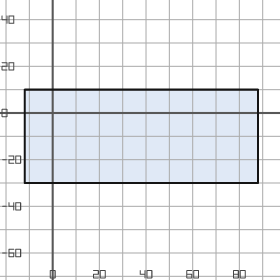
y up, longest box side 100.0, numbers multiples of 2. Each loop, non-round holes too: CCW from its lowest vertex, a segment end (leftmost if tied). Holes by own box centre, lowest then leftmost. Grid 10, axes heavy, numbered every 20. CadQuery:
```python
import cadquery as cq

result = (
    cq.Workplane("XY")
    .moveTo(-12.0, -30.0)
    .lineTo(88.0, -30.0)
    .lineTo(88.0, 10.0)
    .lineTo(-12.0, 10.0)
    .close()
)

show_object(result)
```